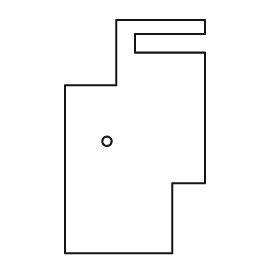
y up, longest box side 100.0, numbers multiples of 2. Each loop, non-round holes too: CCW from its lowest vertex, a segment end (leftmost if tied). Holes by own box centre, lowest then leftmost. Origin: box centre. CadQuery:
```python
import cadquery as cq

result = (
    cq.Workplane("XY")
    .moveTo(-30.0, -50.0)
    .lineTo(16.0, -50.0)
    .lineTo(16.0, -20.0)
    .lineTo(30.0, -20.0)
    .lineTo(30.0, 36.0)
    .lineTo(0.0, 36.0)
    .lineTo(0.0, 44.0)
    .lineTo(30.0, 44.0)
    .lineTo(30.0, 50.0)
    .lineTo(-8.0, 50.0)
    .lineTo(-8.0, 22.0)
    .lineTo(-30.0, 22.0)
    .close()
    .moveTo(-12.0, -2.0)
    .circle(2.0)
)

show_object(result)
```